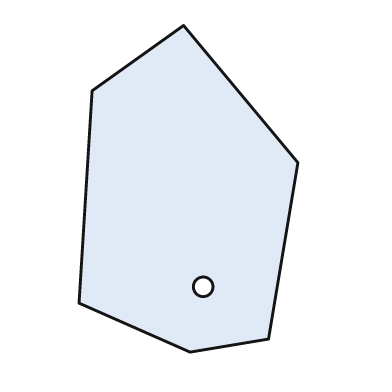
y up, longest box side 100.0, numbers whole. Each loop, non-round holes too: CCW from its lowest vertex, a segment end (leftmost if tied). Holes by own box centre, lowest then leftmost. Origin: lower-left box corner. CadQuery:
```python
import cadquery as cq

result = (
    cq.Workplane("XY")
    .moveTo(34.0, 0.0)
    .lineTo(58.0, 4.0)
    .lineTo(67.0, 58.0)
    .lineTo(32.0, 100.0)
    .lineTo(4.0, 80.0)
    .lineTo(0.0, 15.0)
    .close()
    .moveTo(38.0, 20.0)
    .circle(3.0)
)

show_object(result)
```